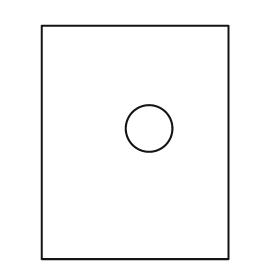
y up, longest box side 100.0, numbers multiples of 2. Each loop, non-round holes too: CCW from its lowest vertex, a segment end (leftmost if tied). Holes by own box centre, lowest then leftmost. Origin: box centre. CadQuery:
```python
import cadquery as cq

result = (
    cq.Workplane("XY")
    .moveTo(-40.0, -50.0)
    .lineTo(40.0, -50.0)
    .lineTo(40.0, 50.0)
    .lineTo(-40.0, 50.0)
    .close()
    .moveTo(6.0, 6.0)
    .circle(10.0)
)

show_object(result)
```